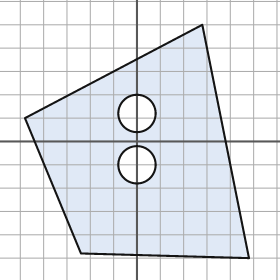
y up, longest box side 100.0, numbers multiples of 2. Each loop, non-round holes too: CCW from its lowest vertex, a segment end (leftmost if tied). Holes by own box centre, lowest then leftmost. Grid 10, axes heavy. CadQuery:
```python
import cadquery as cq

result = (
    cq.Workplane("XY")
    .moveTo(48.0, -50.0)
    .lineTo(28.0, 50.0)
    .lineTo(-48.0, 10.0)
    .lineTo(-24.0, -48.0)
    .close()
    .moveTo(0.0, -10.0)
    .circle(8.0)
    .moveTo(0.0, 12.0)
    .circle(8.0)
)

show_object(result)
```